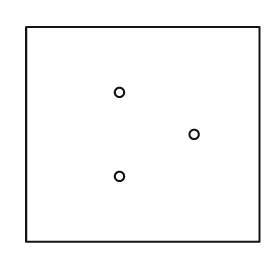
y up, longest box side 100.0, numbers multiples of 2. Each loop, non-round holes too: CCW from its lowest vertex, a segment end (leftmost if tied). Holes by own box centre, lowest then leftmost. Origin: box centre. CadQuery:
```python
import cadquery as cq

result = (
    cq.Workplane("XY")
    .moveTo(-50.0, -46.0)
    .lineTo(50.0, -46.0)
    .lineTo(50.0, 46.0)
    .lineTo(-50.0, 46.0)
    .close()
    .moveTo(-10.0, -18.0)
    .circle(2.0)
    .moveTo(22.0, 0.0)
    .circle(2.0)
    .moveTo(-10.0, 18.0)
    .circle(2.0)
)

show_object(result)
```